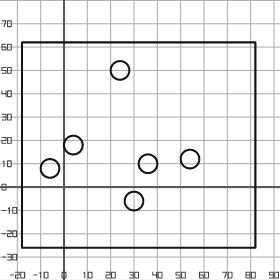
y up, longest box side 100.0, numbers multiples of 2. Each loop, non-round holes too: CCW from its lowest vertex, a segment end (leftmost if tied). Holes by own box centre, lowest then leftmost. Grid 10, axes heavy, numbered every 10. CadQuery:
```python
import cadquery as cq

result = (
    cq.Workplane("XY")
    .moveTo(-18.0, -26.0)
    .lineTo(82.0, -26.0)
    .lineTo(82.0, 62.0)
    .lineTo(-18.0, 62.0)
    .close()
    .moveTo(30.0, -6.0)
    .circle(4.0)
    .moveTo(-6.0, 8.0)
    .circle(4.0)
    .moveTo(36.0, 10.0)
    .circle(4.0)
    .moveTo(54.0, 12.0)
    .circle(4.0)
    .moveTo(4.0, 18.0)
    .circle(4.0)
    .moveTo(24.0, 50.0)
    .circle(4.0)
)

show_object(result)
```